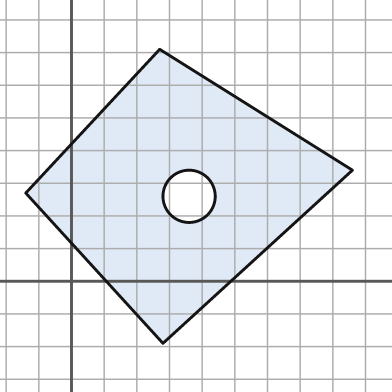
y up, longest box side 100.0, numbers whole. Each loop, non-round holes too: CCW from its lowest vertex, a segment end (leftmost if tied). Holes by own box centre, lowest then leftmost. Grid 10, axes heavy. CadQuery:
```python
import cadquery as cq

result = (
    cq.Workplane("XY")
    .moveTo(28.0, -19.0)
    .lineTo(86.0, 34.0)
    .lineTo(27.0, 71.0)
    .lineTo(-14.0, 27.0)
    .close()
    .moveTo(36.0, 26.0)
    .circle(8.0)
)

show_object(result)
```